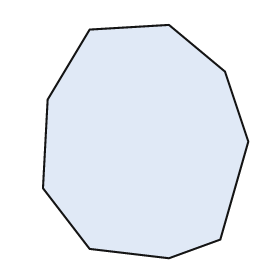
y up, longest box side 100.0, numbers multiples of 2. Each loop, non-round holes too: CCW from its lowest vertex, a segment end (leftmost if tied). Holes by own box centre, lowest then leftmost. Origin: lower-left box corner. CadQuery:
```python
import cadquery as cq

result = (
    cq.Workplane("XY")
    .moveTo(54.0, 0.0)
    .lineTo(76.0, 8.0)
    .lineTo(88.0, 50.0)
    .lineTo(78.0, 80.0)
    .lineTo(54.0, 100.0)
    .lineTo(20.0, 98.0)
    .lineTo(2.0, 68.0)
    .lineTo(0.0, 30.0)
    .lineTo(20.0, 4.0)
    .close()
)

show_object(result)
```